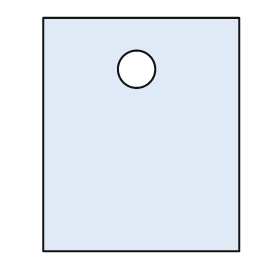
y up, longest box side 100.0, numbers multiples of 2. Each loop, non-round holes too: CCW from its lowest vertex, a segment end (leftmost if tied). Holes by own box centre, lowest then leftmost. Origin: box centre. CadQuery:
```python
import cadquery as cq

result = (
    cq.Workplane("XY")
    .moveTo(-42.0, -50.0)
    .lineTo(42.0, -50.0)
    .lineTo(42.0, 50.0)
    .lineTo(-42.0, 50.0)
    .close()
    .moveTo(-2.0, 28.0)
    .circle(8.0)
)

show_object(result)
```